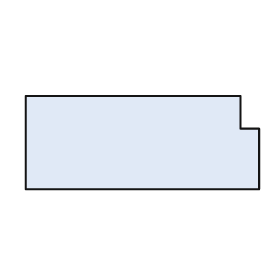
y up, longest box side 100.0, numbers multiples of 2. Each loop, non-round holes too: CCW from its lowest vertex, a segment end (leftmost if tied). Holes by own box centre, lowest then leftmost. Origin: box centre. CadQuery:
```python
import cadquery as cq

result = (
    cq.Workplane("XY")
    .moveTo(-50.0, -20.0)
    .lineTo(50.0, -20.0)
    .lineTo(50.0, 6.0)
    .lineTo(42.0, 6.0)
    .lineTo(42.0, 20.0)
    .lineTo(-50.0, 20.0)
    .close()
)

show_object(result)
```